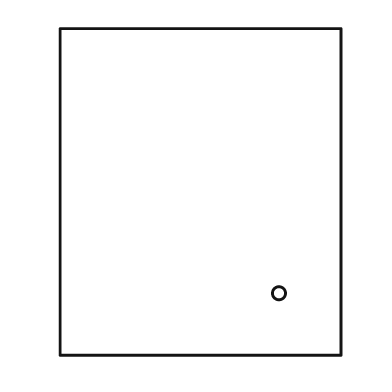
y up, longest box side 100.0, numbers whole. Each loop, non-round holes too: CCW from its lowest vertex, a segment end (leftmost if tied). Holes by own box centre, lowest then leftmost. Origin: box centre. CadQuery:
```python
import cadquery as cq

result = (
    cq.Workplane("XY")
    .moveTo(-43.0, -50.0)
    .lineTo(43.0, -50.0)
    .lineTo(43.0, 50.0)
    .lineTo(-43.0, 50.0)
    .close()
    .moveTo(24.0, -31.0)
    .circle(2.0)
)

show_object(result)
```